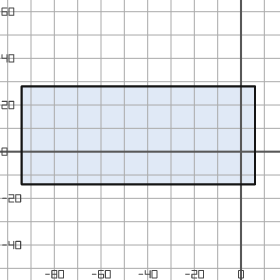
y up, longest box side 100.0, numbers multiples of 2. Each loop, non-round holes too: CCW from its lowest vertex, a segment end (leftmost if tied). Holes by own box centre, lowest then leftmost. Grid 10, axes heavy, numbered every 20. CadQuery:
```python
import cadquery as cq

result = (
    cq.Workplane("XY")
    .moveTo(-94.0, -14.0)
    .lineTo(6.0, -14.0)
    .lineTo(6.0, 28.0)
    .lineTo(-94.0, 28.0)
    .close()
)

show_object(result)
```